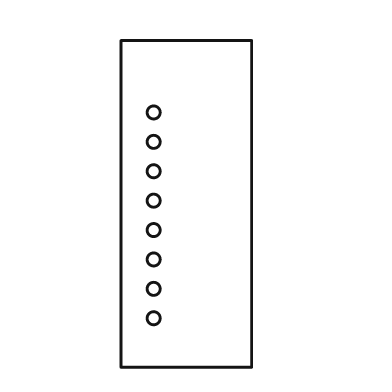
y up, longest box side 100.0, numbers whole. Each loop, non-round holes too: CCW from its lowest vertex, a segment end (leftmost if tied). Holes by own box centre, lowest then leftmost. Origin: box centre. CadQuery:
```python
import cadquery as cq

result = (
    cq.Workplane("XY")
    .moveTo(-20.0, -50.0)
    .lineTo(20.0, -50.0)
    .lineTo(20.0, 50.0)
    .lineTo(-20.0, 50.0)
    .close()
    .moveTo(-10.0, -35.0)
    .circle(2.0)
    .moveTo(-10.0, -26.0)
    .circle(2.0)
    .moveTo(-10.0, -17.0)
    .circle(2.0)
    .moveTo(-10.0, -8.0)
    .circle(2.0)
    .moveTo(-10.0, 1.0)
    .circle(2.0)
    .moveTo(-10.0, 10.0)
    .circle(2.0)
    .moveTo(-10.0, 19.0)
    .circle(2.0)
    .moveTo(-10.0, 28.0)
    .circle(2.0)
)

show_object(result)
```